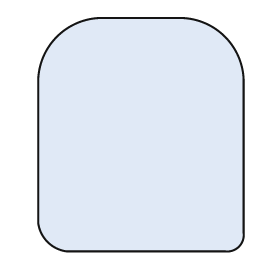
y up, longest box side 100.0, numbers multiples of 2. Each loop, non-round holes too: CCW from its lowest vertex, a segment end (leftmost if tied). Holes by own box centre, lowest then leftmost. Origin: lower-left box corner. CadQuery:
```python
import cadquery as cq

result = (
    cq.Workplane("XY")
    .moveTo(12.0, 0.0)
    .lineTo(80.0, 0.0)
    .threePointArc((86.0, 2.0), (88.0, 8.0))
    .lineTo(88.0, 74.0)
    .threePointArc((80.0, 92.0), (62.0, 100.0))
    .lineTo(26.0, 100.0)
    .threePointArc((8.0, 92.0), (0.0, 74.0))
    .lineTo(0.0, 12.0)
    .threePointArc((4.0, 4.0), (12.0, 0.0))
    .close()
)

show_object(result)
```